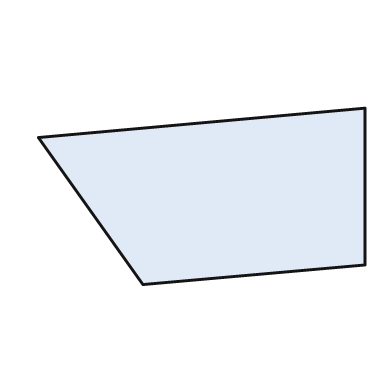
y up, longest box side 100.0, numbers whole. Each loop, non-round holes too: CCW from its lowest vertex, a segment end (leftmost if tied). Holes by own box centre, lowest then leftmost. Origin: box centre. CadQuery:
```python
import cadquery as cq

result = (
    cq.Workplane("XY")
    .moveTo(-18.0, -27.0)
    .lineTo(50.0, -21.0)
    .lineTo(50.0, 27.0)
    .lineTo(-50.0, 18.0)
    .close()
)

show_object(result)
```